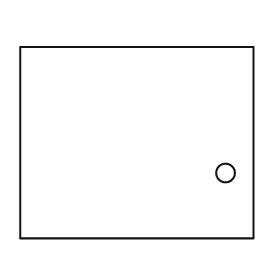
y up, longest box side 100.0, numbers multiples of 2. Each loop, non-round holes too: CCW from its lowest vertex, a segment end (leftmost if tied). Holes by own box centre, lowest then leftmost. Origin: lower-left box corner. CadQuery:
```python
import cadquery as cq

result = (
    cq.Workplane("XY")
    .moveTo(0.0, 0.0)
    .lineTo(100.0, 0.0)
    .lineTo(100.0, 82.0)
    .lineTo(0.0, 82.0)
    .close()
    .moveTo(88.0, 28.0)
    .circle(4.0)
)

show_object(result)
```